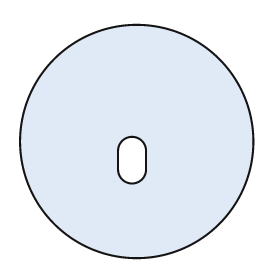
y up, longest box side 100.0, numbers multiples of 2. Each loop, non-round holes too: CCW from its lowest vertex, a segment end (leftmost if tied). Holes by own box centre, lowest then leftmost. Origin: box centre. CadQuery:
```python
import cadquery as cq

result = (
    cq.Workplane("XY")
    .moveTo(0.0, 0.0)
    .circle(50.0)
    .moveTo(-8.0, -12.0)
    .threePointArc((-2.0, -18.0), (4.0, -12.0))
    .lineTo(4.0, -4.0)
    .threePointArc((-2.0, 2.0), (-8.0, -4.0))
    .close()
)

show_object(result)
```